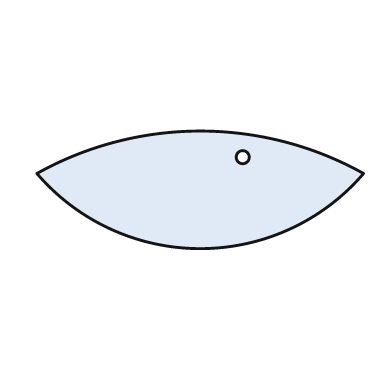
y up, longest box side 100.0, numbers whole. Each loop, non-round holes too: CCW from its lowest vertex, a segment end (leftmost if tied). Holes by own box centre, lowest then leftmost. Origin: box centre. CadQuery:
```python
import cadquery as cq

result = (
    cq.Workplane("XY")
    .moveTo(-50.0, 5.0)
    .threePointArc((0.0, -18.0), (50.0, 5.0))
    .threePointArc((0.0, 18.0), (-50.0, 5.0))
    .close()
    .moveTo(13.0, 10.0)
    .circle(2.0)
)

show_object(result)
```